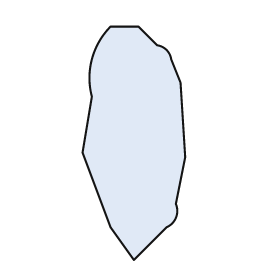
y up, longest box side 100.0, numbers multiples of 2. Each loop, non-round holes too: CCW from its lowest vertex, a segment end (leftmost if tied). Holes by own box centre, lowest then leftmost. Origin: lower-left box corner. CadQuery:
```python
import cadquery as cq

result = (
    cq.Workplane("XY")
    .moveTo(22.0, 0.0)
    .lineTo(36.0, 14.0)
    .threePointArc((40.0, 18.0), (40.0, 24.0))
    .lineTo(44.0, 44.0)
    .lineTo(42.0, 76.0)
    .lineTo(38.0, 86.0)
    .threePointArc((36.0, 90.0), (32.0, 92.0))
    .lineTo(24.0, 100.0)
    .lineTo(12.0, 100.0)
    .threePointArc((4.0, 86.0), (4.0, 70.0))
    .lineTo(0.0, 46.0)
    .lineTo(12.0, 14.0)
    .close()
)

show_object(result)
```